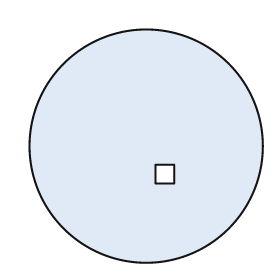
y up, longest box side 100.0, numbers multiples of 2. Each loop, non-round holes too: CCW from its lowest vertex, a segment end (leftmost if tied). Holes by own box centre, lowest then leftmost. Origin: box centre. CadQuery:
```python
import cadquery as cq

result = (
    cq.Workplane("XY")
    .moveTo(0.0, 0.0)
    .circle(50.0)
    .moveTo(4.0, -16.0)
    .lineTo(12.0, -16.0)
    .lineTo(12.0, -8.0)
    .lineTo(4.0, -8.0)
    .close()
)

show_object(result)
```